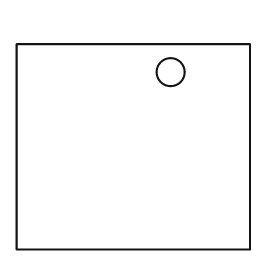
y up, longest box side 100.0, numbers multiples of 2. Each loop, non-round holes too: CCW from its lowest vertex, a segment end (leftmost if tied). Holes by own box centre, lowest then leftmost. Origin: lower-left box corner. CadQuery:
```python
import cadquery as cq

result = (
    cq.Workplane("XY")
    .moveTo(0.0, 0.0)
    .lineTo(100.0, 0.0)
    .lineTo(100.0, 88.0)
    .lineTo(0.0, 88.0)
    .close()
    .moveTo(66.0, 76.0)
    .circle(6.0)
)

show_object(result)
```